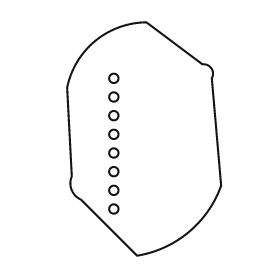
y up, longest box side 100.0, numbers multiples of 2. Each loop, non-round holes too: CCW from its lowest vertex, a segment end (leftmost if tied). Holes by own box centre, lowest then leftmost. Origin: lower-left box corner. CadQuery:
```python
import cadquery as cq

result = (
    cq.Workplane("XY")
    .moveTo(30.0, 0.0)
    .threePointArc((52.0, 10.0), (66.0, 30.0))
    .lineTo(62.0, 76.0)
    .threePointArc((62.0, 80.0), (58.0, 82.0))
    .lineTo(34.0, 100.0)
    .threePointArc((12.0, 92.0), (0.0, 72.0))
    .lineTo(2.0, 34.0)
    .threePointArc((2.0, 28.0), (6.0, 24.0))
    .close()
    .moveTo(20.0, 20.0)
    .circle(2.0)
    .moveTo(20.0, 28.0)
    .circle(2.0)
    .moveTo(20.0, 36.0)
    .circle(2.0)
    .moveTo(20.0, 44.0)
    .circle(2.0)
    .moveTo(20.0, 52.0)
    .circle(2.0)
    .moveTo(20.0, 60.0)
    .circle(2.0)
    .moveTo(20.0, 68.0)
    .circle(2.0)
    .moveTo(20.0, 76.0)
    .circle(2.0)
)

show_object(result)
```